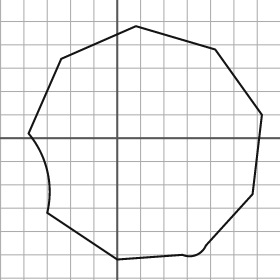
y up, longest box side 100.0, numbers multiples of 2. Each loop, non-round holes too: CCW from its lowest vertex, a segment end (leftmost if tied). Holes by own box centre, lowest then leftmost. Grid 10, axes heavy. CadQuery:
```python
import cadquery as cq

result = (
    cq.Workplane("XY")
    .moveTo(0.0, -52.0)
    .lineTo(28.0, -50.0)
    .threePointArc((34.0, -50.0), (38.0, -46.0))
    .lineTo(58.0, -24.0)
    .lineTo(62.0, 10.0)
    .lineTo(42.0, 38.0)
    .lineTo(8.0, 48.0)
    .lineTo(-24.0, 34.0)
    .lineTo(-38.0, 2.0)
    .threePointArc((-30.0, -14.0), (-30.0, -32.0))
    .close()
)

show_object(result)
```